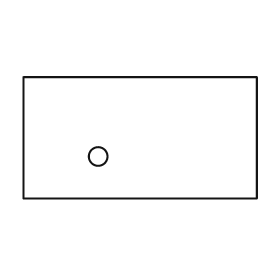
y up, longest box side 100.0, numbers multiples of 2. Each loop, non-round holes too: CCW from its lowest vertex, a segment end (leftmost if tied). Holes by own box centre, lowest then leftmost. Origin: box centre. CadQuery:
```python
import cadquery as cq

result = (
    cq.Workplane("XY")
    .moveTo(-50.0, -26.0)
    .lineTo(50.0, -26.0)
    .lineTo(50.0, 26.0)
    .lineTo(-50.0, 26.0)
    .close()
    .moveTo(-18.0, -8.0)
    .circle(4.0)
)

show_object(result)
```